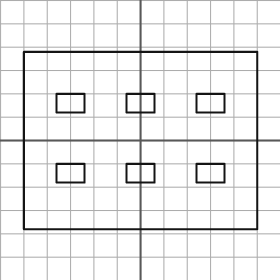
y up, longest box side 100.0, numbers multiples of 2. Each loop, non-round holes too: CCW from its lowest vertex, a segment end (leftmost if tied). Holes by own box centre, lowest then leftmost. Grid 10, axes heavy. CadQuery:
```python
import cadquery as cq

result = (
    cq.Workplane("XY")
    .moveTo(-50.0, -38.0)
    .lineTo(50.0, -38.0)
    .lineTo(50.0, 38.0)
    .lineTo(-50.0, 38.0)
    .close()
    .moveTo(-36.0, -18.0)
    .lineTo(-24.0, -18.0)
    .lineTo(-24.0, -10.0)
    .lineTo(-36.0, -10.0)
    .close()
    .moveTo(-6.0, -18.0)
    .lineTo(6.0, -18.0)
    .lineTo(6.0, -10.0)
    .lineTo(-6.0, -10.0)
    .close()
    .moveTo(24.0, -18.0)
    .lineTo(36.0, -18.0)
    .lineTo(36.0, -10.0)
    .lineTo(24.0, -10.0)
    .close()
    .moveTo(-36.0, 12.0)
    .lineTo(-24.0, 12.0)
    .lineTo(-24.0, 20.0)
    .lineTo(-36.0, 20.0)
    .close()
    .moveTo(-6.0, 12.0)
    .lineTo(6.0, 12.0)
    .lineTo(6.0, 20.0)
    .lineTo(-6.0, 20.0)
    .close()
    .moveTo(24.0, 12.0)
    .lineTo(36.0, 12.0)
    .lineTo(36.0, 20.0)
    .lineTo(24.0, 20.0)
    .close()
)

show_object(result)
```